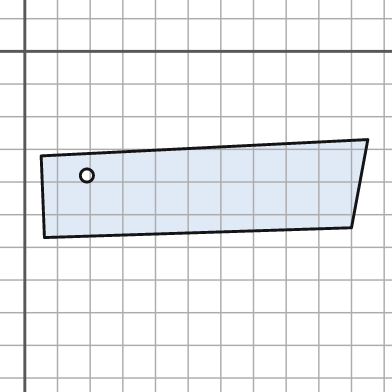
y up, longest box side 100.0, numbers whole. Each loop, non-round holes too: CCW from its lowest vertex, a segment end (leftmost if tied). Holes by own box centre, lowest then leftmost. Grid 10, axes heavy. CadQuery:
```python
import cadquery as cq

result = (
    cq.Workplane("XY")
    .moveTo(6.0, -57.0)
    .lineTo(100.0, -54.0)
    .lineTo(105.0, -27.0)
    .lineTo(5.0, -32.0)
    .close()
    .moveTo(19.0, -38.0)
    .circle(2.0)
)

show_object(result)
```